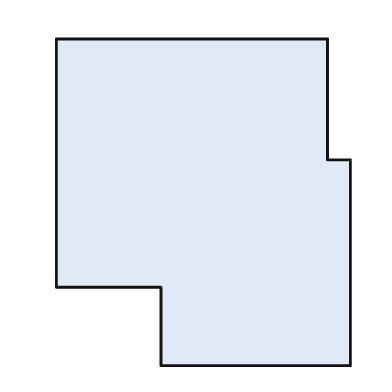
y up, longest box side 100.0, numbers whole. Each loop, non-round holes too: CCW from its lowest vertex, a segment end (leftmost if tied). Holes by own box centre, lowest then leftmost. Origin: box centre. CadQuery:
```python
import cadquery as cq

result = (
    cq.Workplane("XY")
    .moveTo(-13.0, -50.0)
    .lineTo(45.0, -50.0)
    .lineTo(45.0, 13.0)
    .lineTo(38.0, 13.0)
    .lineTo(38.0, 50.0)
    .lineTo(-45.0, 50.0)
    .lineTo(-45.0, -26.0)
    .lineTo(-13.0, -26.0)
    .close()
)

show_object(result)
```